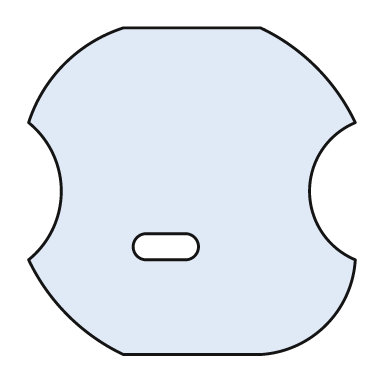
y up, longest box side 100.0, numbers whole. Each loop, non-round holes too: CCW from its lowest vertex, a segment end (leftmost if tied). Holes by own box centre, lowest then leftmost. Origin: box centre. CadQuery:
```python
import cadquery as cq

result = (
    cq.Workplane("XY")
    .moveTo(-21.0, -50.0)
    .lineTo(21.0, -50.0)
    .threePointArc((41.0, -41.0), (50.0, -21.0))
    .threePointArc((36.0, 0.0), (50.0, 21.0))
    .threePointArc((38.0, 38.0), (21.0, 50.0))
    .lineTo(-21.0, 50.0)
    .threePointArc((-39.0, 39.0), (-50.0, 21.0))
    .threePointArc((-40.0, 0.0), (-50.0, -21.0))
    .threePointArc((-38.0, -38.0), (-21.0, -50.0))
    .close()
    .moveTo(-14.0, -21.0)
    .lineTo(-2.0, -21.0)
    .threePointArc((2.0, -17.0), (-2.0, -13.0))
    .lineTo(-14.0, -13.0)
    .threePointArc((-18.0, -17.0), (-14.0, -21.0))
    .close()
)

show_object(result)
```